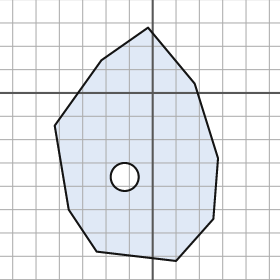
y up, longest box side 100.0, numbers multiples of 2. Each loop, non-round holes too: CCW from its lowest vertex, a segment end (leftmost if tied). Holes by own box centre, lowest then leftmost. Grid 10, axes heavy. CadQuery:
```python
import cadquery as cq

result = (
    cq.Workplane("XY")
    .moveTo(10.0, -72.0)
    .lineTo(26.0, -54.0)
    .lineTo(28.0, -28.0)
    .lineTo(18.0, 4.0)
    .lineTo(-2.0, 28.0)
    .lineTo(-22.0, 14.0)
    .lineTo(-42.0, -14.0)
    .lineTo(-36.0, -50.0)
    .lineTo(-24.0, -68.0)
    .close()
    .moveTo(-12.0, -36.0)
    .circle(6.0)
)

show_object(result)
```